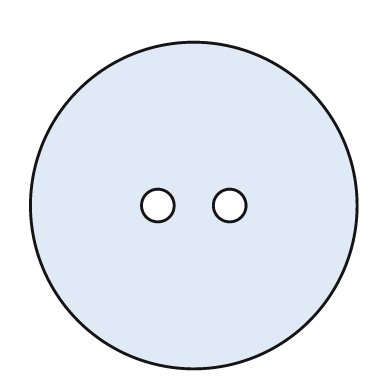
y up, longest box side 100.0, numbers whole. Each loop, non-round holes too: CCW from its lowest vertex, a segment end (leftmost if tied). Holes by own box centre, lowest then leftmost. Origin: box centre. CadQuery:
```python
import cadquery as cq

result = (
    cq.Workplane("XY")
    .moveTo(0.0, 0.0)
    .circle(50.0)
    .moveTo(-11.0, 0.0)
    .circle(5.0)
    .moveTo(11.0, 0.0)
    .circle(5.0)
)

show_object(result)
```